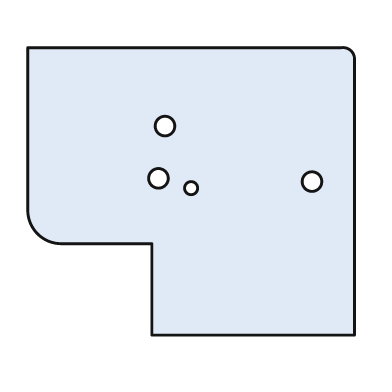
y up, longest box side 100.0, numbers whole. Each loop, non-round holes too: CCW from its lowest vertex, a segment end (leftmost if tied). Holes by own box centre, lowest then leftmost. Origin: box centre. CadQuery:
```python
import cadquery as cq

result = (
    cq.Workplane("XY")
    .moveTo(-12.0, -44.0)
    .lineTo(50.0, -44.0)
    .lineTo(50.0, 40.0)
    .threePointArc((49.0, 43.0), (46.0, 44.0))
    .lineTo(-50.0, 44.0)
    .lineTo(-50.0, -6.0)
    .threePointArc((-47.0, -13.0), (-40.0, -16.0))
    .lineTo(-12.0, -16.0)
    .close()
    .moveTo(0.0, 1.0)
    .circle(2.0)
    .moveTo(37.0, 3.0)
    .circle(3.0)
    .moveTo(-10.0, 4.0)
    .circle(3.0)
    .moveTo(-8.0, 20.0)
    .circle(3.0)
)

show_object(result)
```